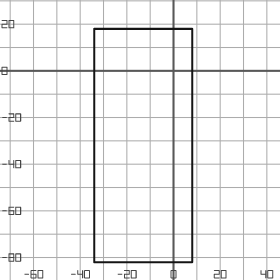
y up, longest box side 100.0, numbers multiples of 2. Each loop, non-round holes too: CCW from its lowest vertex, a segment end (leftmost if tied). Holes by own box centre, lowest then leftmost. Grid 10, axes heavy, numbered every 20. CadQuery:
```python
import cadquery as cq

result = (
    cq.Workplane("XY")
    .moveTo(-34.0, -82.0)
    .lineTo(8.0, -82.0)
    .lineTo(8.0, 18.0)
    .lineTo(-34.0, 18.0)
    .close()
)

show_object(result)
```